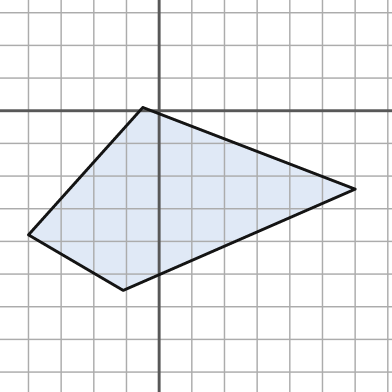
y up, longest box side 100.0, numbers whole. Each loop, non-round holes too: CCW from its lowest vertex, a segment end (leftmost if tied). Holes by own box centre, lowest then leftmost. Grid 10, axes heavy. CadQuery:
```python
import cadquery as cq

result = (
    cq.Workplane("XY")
    .moveTo(-11.0, -55.0)
    .lineTo(60.0, -24.0)
    .lineTo(-5.0, 1.0)
    .lineTo(-40.0, -38.0)
    .close()
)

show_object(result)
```